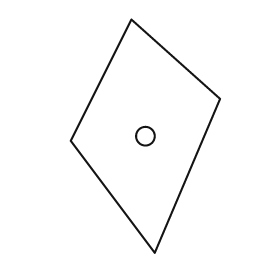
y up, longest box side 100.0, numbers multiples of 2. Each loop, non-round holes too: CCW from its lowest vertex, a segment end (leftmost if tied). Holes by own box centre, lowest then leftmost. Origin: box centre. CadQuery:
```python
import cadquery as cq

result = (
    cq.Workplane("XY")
    .moveTo(4.0, -50.0)
    .lineTo(32.0, 16.0)
    .lineTo(-6.0, 50.0)
    .lineTo(-32.0, -2.0)
    .close()
    .moveTo(0.0, 0.0)
    .circle(4.0)
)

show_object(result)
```